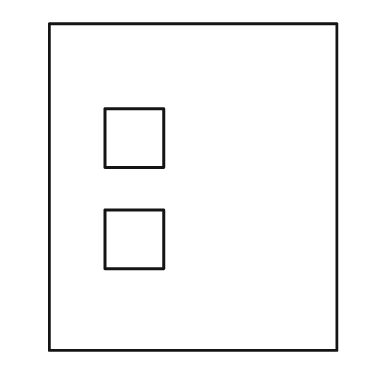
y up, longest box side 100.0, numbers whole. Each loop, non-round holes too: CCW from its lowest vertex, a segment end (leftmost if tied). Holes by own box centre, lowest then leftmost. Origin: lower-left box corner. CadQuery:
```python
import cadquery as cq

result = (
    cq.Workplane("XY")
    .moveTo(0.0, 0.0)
    .lineTo(88.0, 0.0)
    .lineTo(88.0, 100.0)
    .lineTo(0.0, 100.0)
    .close()
    .moveTo(17.0, 25.0)
    .lineTo(35.0, 25.0)
    .lineTo(35.0, 43.0)
    .lineTo(17.0, 43.0)
    .close()
    .moveTo(17.0, 56.0)
    .lineTo(35.0, 56.0)
    .lineTo(35.0, 74.0)
    .lineTo(17.0, 74.0)
    .close()
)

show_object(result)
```